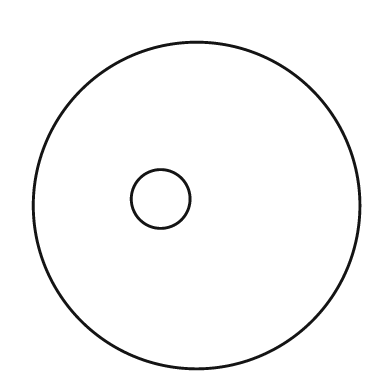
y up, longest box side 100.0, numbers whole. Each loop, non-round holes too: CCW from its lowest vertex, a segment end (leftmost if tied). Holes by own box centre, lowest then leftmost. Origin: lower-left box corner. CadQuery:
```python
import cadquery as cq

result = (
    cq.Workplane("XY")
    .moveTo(50.0, 50.0)
    .circle(50.0)
    .moveTo(39.0, 52.0)
    .circle(9.0)
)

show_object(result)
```